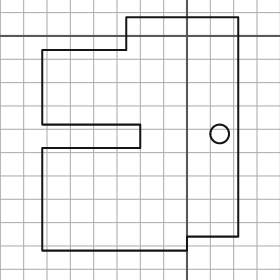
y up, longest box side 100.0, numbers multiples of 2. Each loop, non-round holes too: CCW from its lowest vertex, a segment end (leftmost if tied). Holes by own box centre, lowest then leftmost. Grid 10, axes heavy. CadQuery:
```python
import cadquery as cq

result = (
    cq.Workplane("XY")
    .moveTo(-62.0, -92.0)
    .lineTo(0.0, -92.0)
    .lineTo(0.0, -86.0)
    .lineTo(22.0, -86.0)
    .lineTo(22.0, 8.0)
    .lineTo(-26.0, 8.0)
    .lineTo(-26.0, -6.0)
    .lineTo(-62.0, -6.0)
    .lineTo(-62.0, -38.0)
    .lineTo(-20.0, -38.0)
    .lineTo(-20.0, -48.0)
    .lineTo(-62.0, -48.0)
    .close()
    .moveTo(14.0, -42.0)
    .circle(4.0)
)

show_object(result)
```